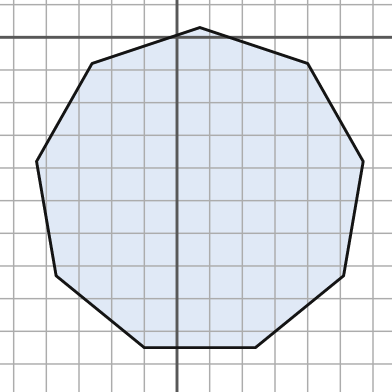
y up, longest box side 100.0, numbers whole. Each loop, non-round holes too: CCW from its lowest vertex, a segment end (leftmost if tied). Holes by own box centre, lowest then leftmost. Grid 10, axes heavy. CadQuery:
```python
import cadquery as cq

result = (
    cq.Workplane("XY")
    .moveTo(-10.0, -95.0)
    .lineTo(24.0, -95.0)
    .lineTo(51.0, -73.0)
    .lineTo(57.0, -38.0)
    .lineTo(40.0, -8.0)
    .lineTo(7.0, 3.0)
    .lineTo(-26.0, -8.0)
    .lineTo(-43.0, -38.0)
    .lineTo(-37.0, -73.0)
    .close()
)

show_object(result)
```